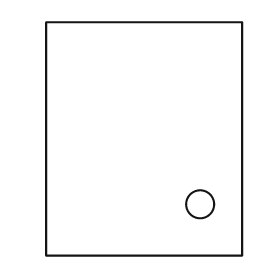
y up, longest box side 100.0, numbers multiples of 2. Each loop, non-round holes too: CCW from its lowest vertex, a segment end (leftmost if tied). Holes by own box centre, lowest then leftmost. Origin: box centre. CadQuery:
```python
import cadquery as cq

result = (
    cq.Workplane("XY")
    .moveTo(-42.0, -50.0)
    .lineTo(42.0, -50.0)
    .lineTo(42.0, 50.0)
    .lineTo(-42.0, 50.0)
    .close()
    .moveTo(24.0, -28.0)
    .circle(6.0)
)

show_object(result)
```